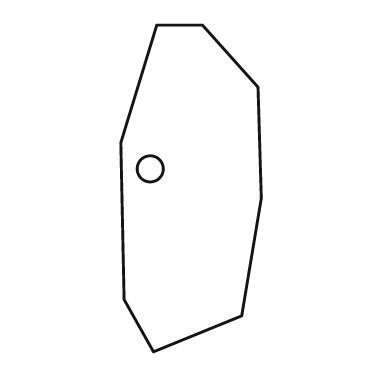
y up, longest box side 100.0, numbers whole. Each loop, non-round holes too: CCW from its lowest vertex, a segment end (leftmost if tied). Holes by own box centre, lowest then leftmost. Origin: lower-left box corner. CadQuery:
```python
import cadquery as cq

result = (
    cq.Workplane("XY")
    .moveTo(10.0, 0.0)
    .lineTo(37.0, 11.0)
    .lineTo(43.0, 47.0)
    .lineTo(42.0, 81.0)
    .lineTo(25.0, 100.0)
    .lineTo(11.0, 100.0)
    .lineTo(0.0, 64.0)
    .lineTo(1.0, 16.0)
    .close()
    .moveTo(9.0, 56.0)
    .circle(4.0)
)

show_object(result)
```